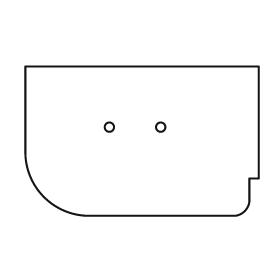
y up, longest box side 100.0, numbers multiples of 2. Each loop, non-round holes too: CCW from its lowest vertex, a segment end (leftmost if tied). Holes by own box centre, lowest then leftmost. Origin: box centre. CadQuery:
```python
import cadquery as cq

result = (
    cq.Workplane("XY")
    .moveTo(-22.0, -32.0)
    .lineTo(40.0, -32.0)
    .threePointArc((44.0, -30.0), (46.0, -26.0))
    .lineTo(46.0, -16.0)
    .lineTo(50.0, -16.0)
    .lineTo(50.0, 32.0)
    .lineTo(-50.0, 32.0)
    .lineTo(-50.0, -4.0)
    .threePointArc((-42.0, -24.0), (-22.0, -32.0))
    .close()
    .moveTo(-14.0, 6.0)
    .circle(2.0)
    .moveTo(8.0, 6.0)
    .circle(2.0)
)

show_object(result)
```